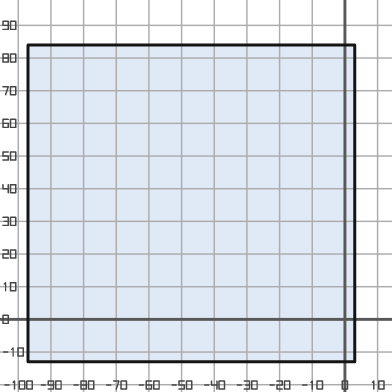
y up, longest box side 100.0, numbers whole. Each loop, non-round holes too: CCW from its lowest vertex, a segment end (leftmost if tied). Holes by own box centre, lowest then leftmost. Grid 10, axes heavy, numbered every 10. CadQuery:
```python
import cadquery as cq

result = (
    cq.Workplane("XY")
    .moveTo(-97.0, -13.0)
    .lineTo(3.0, -13.0)
    .lineTo(3.0, 84.0)
    .lineTo(-97.0, 84.0)
    .close()
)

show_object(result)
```